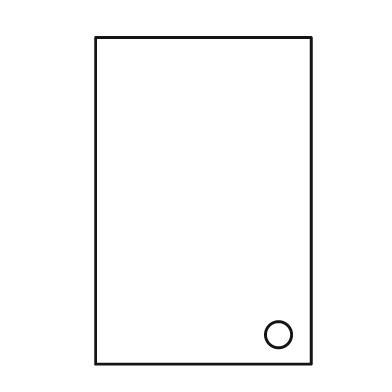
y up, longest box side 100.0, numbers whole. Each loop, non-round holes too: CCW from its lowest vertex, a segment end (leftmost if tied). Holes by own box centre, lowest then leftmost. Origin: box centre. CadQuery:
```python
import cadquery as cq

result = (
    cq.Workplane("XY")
    .moveTo(-33.0, -50.0)
    .lineTo(33.0, -50.0)
    .lineTo(33.0, 50.0)
    .lineTo(-33.0, 50.0)
    .close()
    .moveTo(23.0, -41.0)
    .circle(4.0)
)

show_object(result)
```